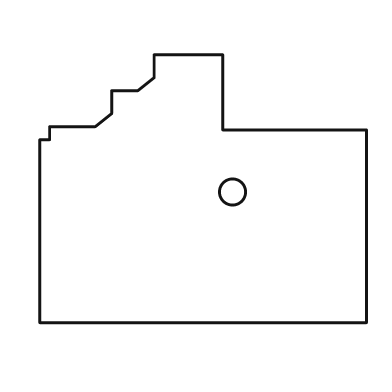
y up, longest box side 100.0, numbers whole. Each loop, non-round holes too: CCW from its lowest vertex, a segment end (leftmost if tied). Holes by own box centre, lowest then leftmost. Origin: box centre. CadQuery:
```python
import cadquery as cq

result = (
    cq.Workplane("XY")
    .moveTo(-50.0, -41.0)
    .lineTo(50.0, -41.0)
    .lineTo(50.0, 18.0)
    .lineTo(6.0, 18.0)
    .lineTo(6.0, 41.0)
    .lineTo(-15.0, 41.0)
    .lineTo(-15.0, 34.0)
    .lineTo(-20.0, 30.0)
    .lineTo(-28.0, 30.0)
    .lineTo(-28.0, 23.0)
    .lineTo(-33.0, 19.0)
    .lineTo(-47.0, 19.0)
    .lineTo(-47.0, 15.0)
    .lineTo(-50.0, 15.0)
    .close()
    .moveTo(9.0, -1.0)
    .circle(4.0)
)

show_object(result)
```